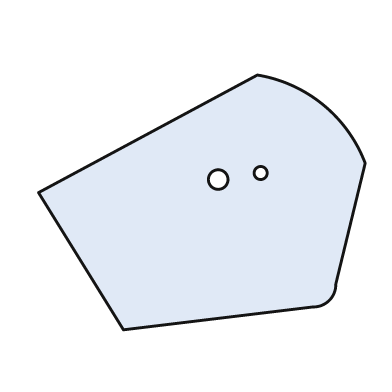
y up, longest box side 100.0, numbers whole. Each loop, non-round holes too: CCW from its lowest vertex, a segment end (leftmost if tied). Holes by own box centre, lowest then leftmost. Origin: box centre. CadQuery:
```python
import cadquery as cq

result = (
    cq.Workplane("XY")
    .moveTo(-24.0, -39.0)
    .lineTo(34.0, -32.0)
    .threePointArc((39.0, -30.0), (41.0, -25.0))
    .lineTo(50.0, 12.0)
    .threePointArc((37.0, 30.0), (17.0, 39.0))
    .lineTo(-50.0, 3.0)
    .close()
    .moveTo(5.0, 7.0)
    .circle(3.0)
    .moveTo(18.0, 9.0)
    .circle(2.0)
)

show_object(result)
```